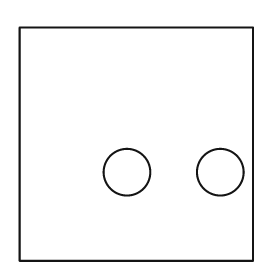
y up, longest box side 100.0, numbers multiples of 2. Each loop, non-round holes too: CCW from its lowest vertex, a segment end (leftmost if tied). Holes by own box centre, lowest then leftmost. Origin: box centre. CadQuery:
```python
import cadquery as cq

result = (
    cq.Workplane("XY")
    .moveTo(-50.0, -50.0)
    .lineTo(50.0, -50.0)
    .lineTo(50.0, 50.0)
    .lineTo(-50.0, 50.0)
    .close()
    .moveTo(-4.0, -12.0)
    .circle(10.0)
    .moveTo(36.0, -12.0)
    .circle(10.0)
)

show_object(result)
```